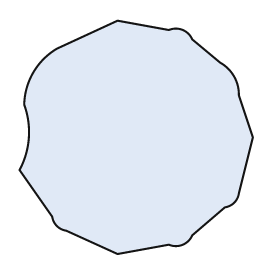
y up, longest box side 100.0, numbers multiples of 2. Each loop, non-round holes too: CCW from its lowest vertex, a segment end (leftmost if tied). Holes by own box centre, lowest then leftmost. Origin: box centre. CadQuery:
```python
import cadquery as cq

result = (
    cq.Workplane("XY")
    .moveTo(-8.0, -50.0)
    .lineTo(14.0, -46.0)
    .threePointArc((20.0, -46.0), (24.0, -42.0))
    .lineTo(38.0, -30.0)
    .threePointArc((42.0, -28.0), (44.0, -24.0))
    .lineTo(50.0, 0.0)
    .lineTo(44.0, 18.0)
    .threePointArc((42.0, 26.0), (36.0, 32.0))
    .lineTo(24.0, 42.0)
    .threePointArc((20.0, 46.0), (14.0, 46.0))
    .lineTo(-8.0, 50.0)
    .lineTo(-34.0, 38.0)
    .threePointArc((-44.0, 28.0), (-48.0, 14.0))
    .threePointArc((-46.0, 0.0), (-50.0, -14.0))
    .lineTo(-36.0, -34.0)
    .threePointArc((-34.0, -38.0), (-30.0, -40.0))
    .close()
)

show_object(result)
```